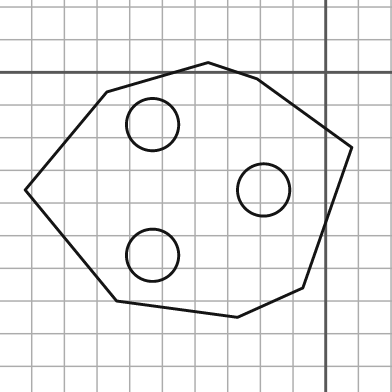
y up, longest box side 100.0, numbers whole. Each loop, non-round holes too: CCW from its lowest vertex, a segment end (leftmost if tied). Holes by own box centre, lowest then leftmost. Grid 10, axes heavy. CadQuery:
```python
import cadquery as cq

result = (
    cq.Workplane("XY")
    .moveTo(-27.0, -75.0)
    .lineTo(-7.0, -66.0)
    .lineTo(8.0, -23.0)
    .lineTo(-21.0, -2.0)
    .lineTo(-36.0, 3.0)
    .lineTo(-67.0, -6.0)
    .lineTo(-92.0, -36.0)
    .lineTo(-64.0, -70.0)
    .close()
    .moveTo(-53.0, -56.0)
    .circle(8.0)
    .moveTo(-19.0, -36.0)
    .circle(8.0)
    .moveTo(-53.0, -16.0)
    .circle(8.0)
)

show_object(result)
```